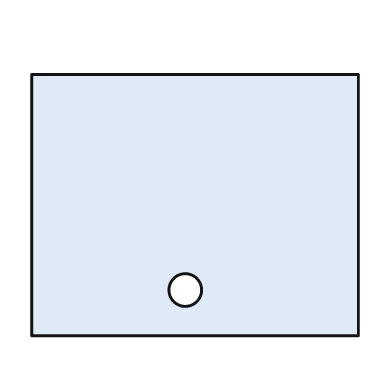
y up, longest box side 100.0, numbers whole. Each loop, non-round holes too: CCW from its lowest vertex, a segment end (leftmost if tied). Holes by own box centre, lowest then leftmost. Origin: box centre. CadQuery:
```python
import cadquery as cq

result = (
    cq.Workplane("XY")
    .moveTo(-50.0, -40.0)
    .lineTo(50.0, -40.0)
    .lineTo(50.0, 40.0)
    .lineTo(-50.0, 40.0)
    .close()
    .moveTo(-3.0, -26.0)
    .circle(5.0)
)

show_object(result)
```